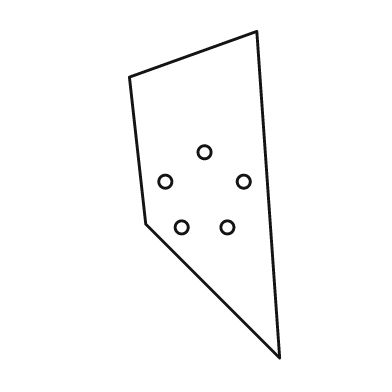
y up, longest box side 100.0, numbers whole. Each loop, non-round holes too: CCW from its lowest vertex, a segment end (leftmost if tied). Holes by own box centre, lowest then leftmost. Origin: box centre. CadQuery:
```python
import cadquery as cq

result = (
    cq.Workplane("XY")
    .moveTo(23.0, -50.0)
    .lineTo(16.0, 50.0)
    .lineTo(-23.0, 36.0)
    .lineTo(-18.0, -9.0)
    .close()
    .moveTo(-7.0, -10.0)
    .circle(2.0)
    .moveTo(7.0, -10.0)
    .circle(2.0)
    .moveTo(-12.0, 4.0)
    .circle(2.0)
    .moveTo(12.0, 4.0)
    .circle(2.0)
    .moveTo(0.0, 13.0)
    .circle(2.0)
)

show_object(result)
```